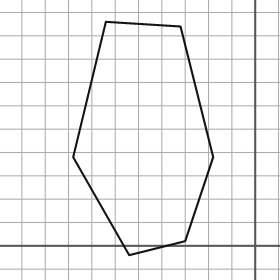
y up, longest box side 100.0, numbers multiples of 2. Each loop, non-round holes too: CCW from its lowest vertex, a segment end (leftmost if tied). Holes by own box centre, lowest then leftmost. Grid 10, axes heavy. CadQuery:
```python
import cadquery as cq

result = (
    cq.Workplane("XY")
    .moveTo(-54.0, -4.0)
    .lineTo(-30.0, 2.0)
    .lineTo(-18.0, 38.0)
    .lineTo(-32.0, 94.0)
    .lineTo(-64.0, 96.0)
    .lineTo(-78.0, 38.0)
    .close()
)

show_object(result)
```